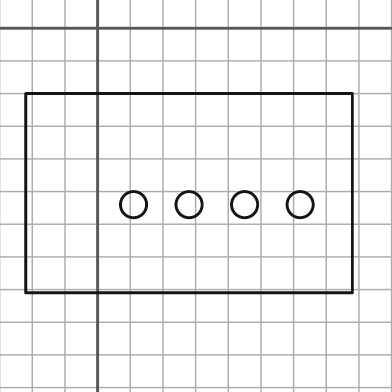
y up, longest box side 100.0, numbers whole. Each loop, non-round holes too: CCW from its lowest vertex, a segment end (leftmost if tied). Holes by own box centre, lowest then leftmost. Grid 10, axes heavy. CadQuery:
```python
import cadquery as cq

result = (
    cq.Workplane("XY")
    .moveTo(-22.0, -81.0)
    .lineTo(78.0, -81.0)
    .lineTo(78.0, -20.0)
    .lineTo(-22.0, -20.0)
    .close()
    .moveTo(11.0, -54.0)
    .circle(4.0)
    .moveTo(28.0, -54.0)
    .circle(4.0)
    .moveTo(45.0, -54.0)
    .circle(4.0)
    .moveTo(62.0, -54.0)
    .circle(4.0)
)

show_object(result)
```